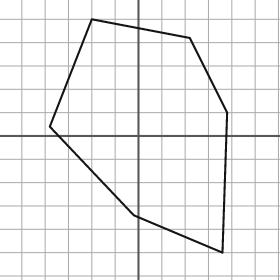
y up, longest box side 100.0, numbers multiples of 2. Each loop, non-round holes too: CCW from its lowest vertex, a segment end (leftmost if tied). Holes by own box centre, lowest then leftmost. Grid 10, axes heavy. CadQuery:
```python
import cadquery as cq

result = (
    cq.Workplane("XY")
    .moveTo(36.0, -50.0)
    .lineTo(38.0, 10.0)
    .lineTo(22.0, 42.0)
    .lineTo(-20.0, 50.0)
    .lineTo(-38.0, 4.0)
    .lineTo(-2.0, -34.0)
    .close()
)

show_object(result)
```